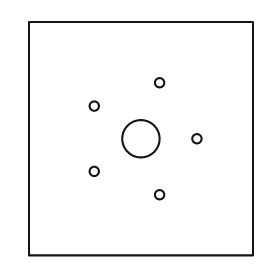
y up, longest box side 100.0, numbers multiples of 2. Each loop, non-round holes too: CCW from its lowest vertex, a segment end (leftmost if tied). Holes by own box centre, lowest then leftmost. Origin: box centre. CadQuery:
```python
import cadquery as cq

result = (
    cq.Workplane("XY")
    .moveTo(-48.0, -50.0)
    .lineTo(48.0, -50.0)
    .lineTo(48.0, 50.0)
    .lineTo(-48.0, 50.0)
    .close()
    .moveTo(8.0, -24.0)
    .circle(2.0)
    .moveTo(-20.0, -14.0)
    .circle(2.0)
    .moveTo(0.0, 0.0)
    .circle(8.0)
    .moveTo(24.0, 0.0)
    .circle(2.0)
    .moveTo(-20.0, 14.0)
    .circle(2.0)
    .moveTo(8.0, 24.0)
    .circle(2.0)
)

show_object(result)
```